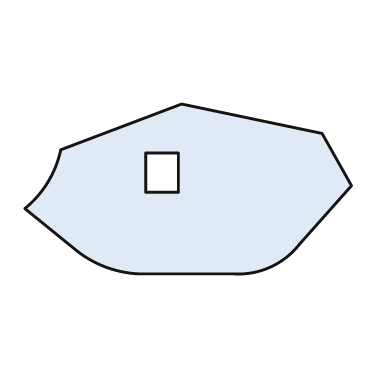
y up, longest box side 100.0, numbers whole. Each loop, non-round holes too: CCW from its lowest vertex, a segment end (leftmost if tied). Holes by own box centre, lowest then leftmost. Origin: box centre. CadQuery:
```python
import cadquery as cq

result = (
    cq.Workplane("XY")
    .moveTo(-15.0, -26.0)
    .lineTo(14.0, -26.0)
    .threePointArc((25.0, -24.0), (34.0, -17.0))
    .lineTo(50.0, 1.0)
    .lineTo(41.0, 17.0)
    .lineTo(-2.0, 26.0)
    .lineTo(-39.0, 12.0)
    .threePointArc((-43.0, 2.0), (-50.0, -6.0))
    .lineTo(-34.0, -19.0)
    .threePointArc((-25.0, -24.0), (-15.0, -26.0))
    .close()
    .moveTo(-13.0, -1.0)
    .lineTo(-3.0, -1.0)
    .lineTo(-3.0, 11.0)
    .lineTo(-13.0, 11.0)
    .close()
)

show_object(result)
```